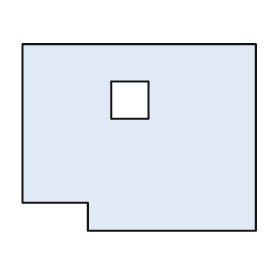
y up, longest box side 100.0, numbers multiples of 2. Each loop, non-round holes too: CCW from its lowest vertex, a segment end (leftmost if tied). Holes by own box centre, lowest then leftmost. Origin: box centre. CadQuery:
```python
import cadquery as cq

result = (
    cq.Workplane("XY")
    .moveTo(-22.0, -40.0)
    .lineTo(50.0, -40.0)
    .lineTo(50.0, 40.0)
    .lineTo(-50.0, 40.0)
    .lineTo(-50.0, -28.0)
    .lineTo(-22.0, -28.0)
    .close()
    .moveTo(-12.0, 8.0)
    .lineTo(4.0, 8.0)
    .lineTo(4.0, 24.0)
    .lineTo(-12.0, 24.0)
    .close()
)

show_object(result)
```